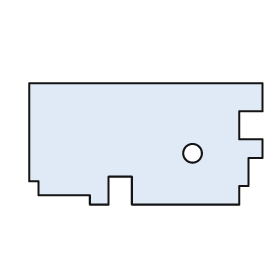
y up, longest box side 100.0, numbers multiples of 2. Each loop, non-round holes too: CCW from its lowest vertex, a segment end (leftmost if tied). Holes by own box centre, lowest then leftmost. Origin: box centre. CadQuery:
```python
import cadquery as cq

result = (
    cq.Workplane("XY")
    .moveTo(-24.0, -26.0)
    .lineTo(-16.0, -26.0)
    .lineTo(-16.0, -14.0)
    .lineTo(-6.0, -14.0)
    .lineTo(-6.0, -26.0)
    .lineTo(40.0, -26.0)
    .lineTo(40.0, -18.0)
    .lineTo(44.0, -18.0)
    .lineTo(44.0, -6.0)
    .lineTo(50.0, -6.0)
    .lineTo(50.0, 2.0)
    .lineTo(40.0, 2.0)
    .lineTo(40.0, 14.0)
    .lineTo(50.0, 14.0)
    .lineTo(50.0, 26.0)
    .lineTo(-50.0, 26.0)
    .lineTo(-50.0, -16.0)
    .lineTo(-46.0, -16.0)
    .lineTo(-46.0, -22.0)
    .lineTo(-24.0, -22.0)
    .close()
    .moveTo(20.0, -4.0)
    .circle(4.0)
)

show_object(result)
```